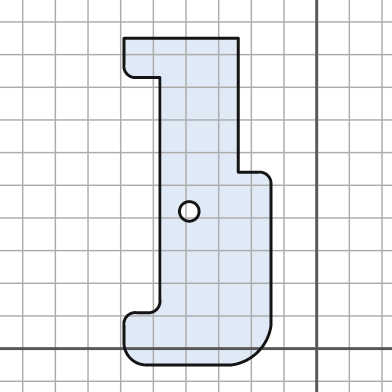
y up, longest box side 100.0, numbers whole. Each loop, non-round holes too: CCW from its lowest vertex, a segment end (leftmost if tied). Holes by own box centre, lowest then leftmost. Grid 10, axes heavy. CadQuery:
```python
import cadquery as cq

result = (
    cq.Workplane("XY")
    .moveTo(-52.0, -5.0)
    .lineTo(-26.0, -5.0)
    .threePointArc((-18.0, -1.0), (-14.0, 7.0))
    .lineTo(-14.0, 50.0)
    .threePointArc((-15.0, 53.0), (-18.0, 54.0))
    .lineTo(-24.0, 54.0)
    .lineTo(-24.0, 95.0)
    .lineTo(-59.0, 95.0)
    .lineTo(-59.0, 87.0)
    .threePointArc((-58.0, 84.0), (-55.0, 83.0))
    .lineTo(-48.0, 83.0)
    .lineTo(-48.0, 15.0)
    .threePointArc((-49.0, 12.0), (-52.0, 11.0))
    .lineTo(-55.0, 11.0)
    .threePointArc((-58.0, 10.0), (-59.0, 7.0))
    .lineTo(-59.0, 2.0)
    .threePointArc((-57.0, -3.0), (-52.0, -5.0))
    .close()
    .moveTo(-39.0, 42.0)
    .circle(3.0)
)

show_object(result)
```